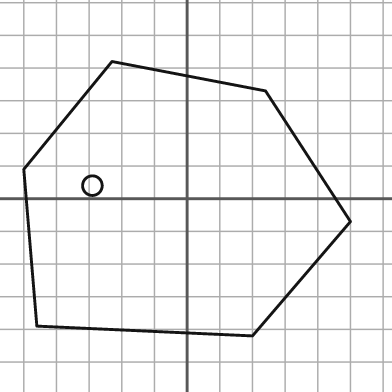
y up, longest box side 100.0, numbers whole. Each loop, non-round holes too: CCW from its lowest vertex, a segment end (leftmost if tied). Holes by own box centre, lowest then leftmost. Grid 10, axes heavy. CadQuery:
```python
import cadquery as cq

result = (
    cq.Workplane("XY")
    .moveTo(20.0, -42.0)
    .lineTo(50.0, -7.0)
    .lineTo(24.0, 33.0)
    .lineTo(-23.0, 42.0)
    .lineTo(-50.0, 9.0)
    .lineTo(-46.0, -39.0)
    .close()
    .moveTo(-29.0, 4.0)
    .circle(3.0)
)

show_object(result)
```